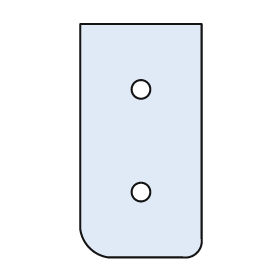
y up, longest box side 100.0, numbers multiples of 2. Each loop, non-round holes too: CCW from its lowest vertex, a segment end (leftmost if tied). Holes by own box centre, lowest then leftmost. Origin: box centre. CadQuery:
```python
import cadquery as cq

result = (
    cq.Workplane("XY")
    .moveTo(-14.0, -50.0)
    .lineTo(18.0, -50.0)
    .threePointArc((24.0, -48.0), (26.0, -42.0))
    .lineTo(26.0, 50.0)
    .lineTo(-26.0, 50.0)
    .lineTo(-26.0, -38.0)
    .threePointArc((-22.0, -46.0), (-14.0, -50.0))
    .close()
    .moveTo(0.0, -22.0)
    .circle(4.0)
    .moveTo(0.0, 22.0)
    .circle(4.0)
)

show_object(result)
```